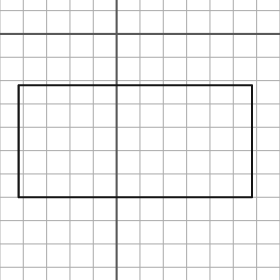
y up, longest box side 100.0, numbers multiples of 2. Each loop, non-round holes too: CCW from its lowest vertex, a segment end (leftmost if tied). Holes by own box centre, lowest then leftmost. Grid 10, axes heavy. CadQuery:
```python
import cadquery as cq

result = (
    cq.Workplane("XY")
    .moveTo(-42.0, -70.0)
    .lineTo(58.0, -70.0)
    .lineTo(58.0, -22.0)
    .lineTo(-42.0, -22.0)
    .close()
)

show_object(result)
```